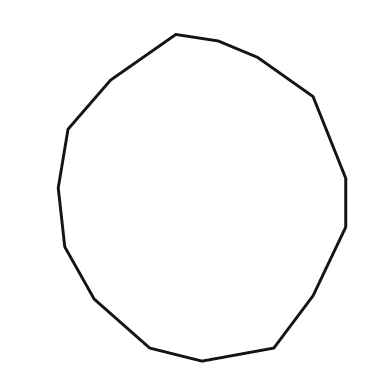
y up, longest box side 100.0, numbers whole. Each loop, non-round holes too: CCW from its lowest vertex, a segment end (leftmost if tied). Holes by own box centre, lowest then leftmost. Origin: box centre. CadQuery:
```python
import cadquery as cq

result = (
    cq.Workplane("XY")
    .moveTo(0.0, -50.0)
    .lineTo(22.0, -46.0)
    .lineTo(34.0, -30.0)
    .lineTo(44.0, -9.0)
    .lineTo(44.0, 6.0)
    .lineTo(34.0, 31.0)
    .lineTo(17.0, 43.0)
    .lineTo(5.0, 48.0)
    .lineTo(-8.0, 50.0)
    .lineTo(-28.0, 36.0)
    .lineTo(-41.0, 21.0)
    .lineTo(-44.0, 3.0)
    .lineTo(-42.0, -15.0)
    .lineTo(-33.0, -31.0)
    .lineTo(-16.0, -46.0)
    .close()
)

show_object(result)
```